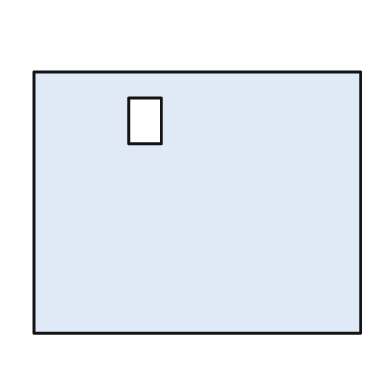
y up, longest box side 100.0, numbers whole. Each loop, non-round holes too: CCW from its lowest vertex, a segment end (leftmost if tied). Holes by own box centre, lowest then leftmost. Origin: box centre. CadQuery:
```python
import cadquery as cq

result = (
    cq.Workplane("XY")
    .moveTo(-50.0, -40.0)
    .lineTo(50.0, -40.0)
    .lineTo(50.0, 40.0)
    .lineTo(-50.0, 40.0)
    .close()
    .moveTo(-21.0, 18.0)
    .lineTo(-11.0, 18.0)
    .lineTo(-11.0, 32.0)
    .lineTo(-21.0, 32.0)
    .close()
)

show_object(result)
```